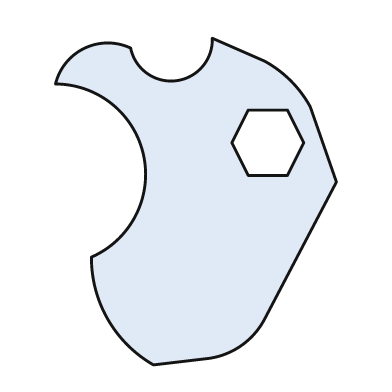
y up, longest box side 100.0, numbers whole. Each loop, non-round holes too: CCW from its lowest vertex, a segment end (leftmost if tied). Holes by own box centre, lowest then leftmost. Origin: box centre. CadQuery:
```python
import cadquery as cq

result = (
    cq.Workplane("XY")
    .moveTo(-13.0, -50.0)
    .lineTo(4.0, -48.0)
    .threePointArc((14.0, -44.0), (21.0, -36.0))
    .lineTo(43.0, 6.0)
    .lineTo(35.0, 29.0)
    .threePointArc((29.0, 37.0), (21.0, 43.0))
    .lineTo(5.0, 50.0)
    .threePointArc((-6.0, 37.0), (-20.0, 47.0))
    .threePointArc((-34.0, 47.0), (-43.0, 36.0))
    .threePointArc((-16.0, 14.0), (-32.0, -17.0))
    .threePointArc((-27.0, -36.0), (-13.0, -50.0))
    .close()
    .moveTo(16.0, 8.0)
    .lineTo(28.0, 8.0)
    .lineTo(33.0, 18.0)
    .lineTo(28.0, 28.0)
    .lineTo(16.0, 28.0)
    .lineTo(11.0, 18.0)
    .close()
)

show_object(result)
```